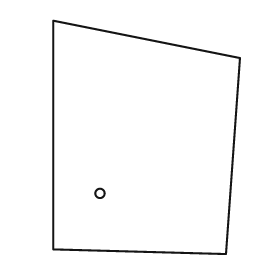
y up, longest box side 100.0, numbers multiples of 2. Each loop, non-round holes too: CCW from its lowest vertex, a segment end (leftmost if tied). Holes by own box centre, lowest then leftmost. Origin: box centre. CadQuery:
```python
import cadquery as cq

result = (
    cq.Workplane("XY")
    .moveTo(34.0, -50.0)
    .lineTo(40.0, 34.0)
    .lineTo(-40.0, 50.0)
    .lineTo(-40.0, -48.0)
    .close()
    .moveTo(-20.0, -24.0)
    .circle(2.0)
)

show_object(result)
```